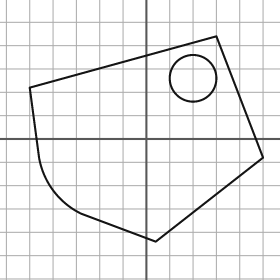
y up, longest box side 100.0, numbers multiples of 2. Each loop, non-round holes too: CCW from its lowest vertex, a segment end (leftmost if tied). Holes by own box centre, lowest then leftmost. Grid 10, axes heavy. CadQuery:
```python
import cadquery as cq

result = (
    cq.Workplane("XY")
    .moveTo(4.0, -44.0)
    .lineTo(50.0, -8.0)
    .lineTo(30.0, 44.0)
    .lineTo(-50.0, 22.0)
    .lineTo(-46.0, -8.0)
    .threePointArc((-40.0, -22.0), (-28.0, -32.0))
    .close()
    .moveTo(20.0, 26.0)
    .circle(10.0)
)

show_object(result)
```